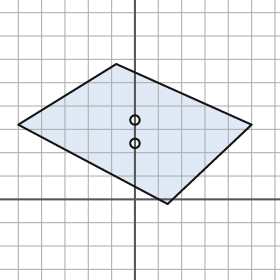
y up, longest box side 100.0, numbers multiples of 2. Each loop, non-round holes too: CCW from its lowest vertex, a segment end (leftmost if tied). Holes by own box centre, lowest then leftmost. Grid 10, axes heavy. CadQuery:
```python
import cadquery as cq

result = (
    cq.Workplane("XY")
    .moveTo(14.0, -2.0)
    .lineTo(50.0, 32.0)
    .lineTo(-8.0, 58.0)
    .lineTo(-50.0, 32.0)
    .close()
    .moveTo(0.0, 24.0)
    .circle(2.0)
    .moveTo(0.0, 34.0)
    .circle(2.0)
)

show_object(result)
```